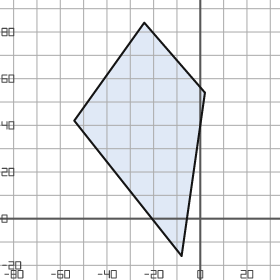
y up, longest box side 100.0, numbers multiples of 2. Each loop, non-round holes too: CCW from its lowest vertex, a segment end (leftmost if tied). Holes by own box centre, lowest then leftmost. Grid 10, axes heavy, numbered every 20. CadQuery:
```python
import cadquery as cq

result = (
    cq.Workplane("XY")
    .moveTo(-8.0, -16.0)
    .lineTo(2.0, 54.0)
    .lineTo(-24.0, 84.0)
    .lineTo(-54.0, 42.0)
    .close()
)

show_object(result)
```